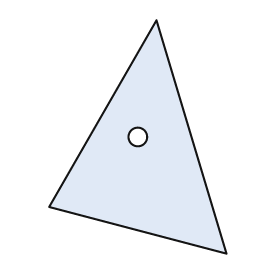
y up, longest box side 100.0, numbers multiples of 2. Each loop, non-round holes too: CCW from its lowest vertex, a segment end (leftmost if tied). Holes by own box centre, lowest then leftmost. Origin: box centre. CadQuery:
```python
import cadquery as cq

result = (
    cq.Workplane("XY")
    .moveTo(38.0, -50.0)
    .lineTo(8.0, 50.0)
    .lineTo(-38.0, -30.0)
    .close()
    .moveTo(0.0, 0.0)
    .circle(4.0)
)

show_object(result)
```